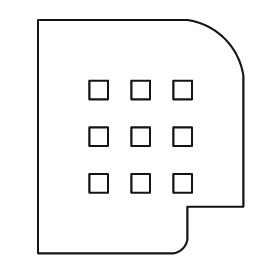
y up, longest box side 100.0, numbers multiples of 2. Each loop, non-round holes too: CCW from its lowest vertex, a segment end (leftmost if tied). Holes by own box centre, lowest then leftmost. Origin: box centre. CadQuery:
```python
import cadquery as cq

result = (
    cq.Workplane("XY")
    .moveTo(-44.0, -50.0)
    .lineTo(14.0, -50.0)
    .threePointArc((18.0, -48.0), (20.0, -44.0))
    .lineTo(20.0, -30.0)
    .lineTo(44.0, -30.0)
    .lineTo(44.0, 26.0)
    .threePointArc((36.0, 42.0), (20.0, 50.0))
    .lineTo(-44.0, 50.0)
    .close()
    .moveTo(-22.0, -24.0)
    .lineTo(-14.0, -24.0)
    .lineTo(-14.0, -16.0)
    .lineTo(-22.0, -16.0)
    .close()
    .moveTo(-4.0, -24.0)
    .lineTo(4.0, -24.0)
    .lineTo(4.0, -16.0)
    .lineTo(-4.0, -16.0)
    .close()
    .moveTo(14.0, -24.0)
    .lineTo(22.0, -24.0)
    .lineTo(22.0, -16.0)
    .lineTo(14.0, -16.0)
    .close()
    .moveTo(-22.0, -4.0)
    .lineTo(-14.0, -4.0)
    .lineTo(-14.0, 4.0)
    .lineTo(-22.0, 4.0)
    .close()
    .moveTo(-4.0, -4.0)
    .lineTo(4.0, -4.0)
    .lineTo(4.0, 4.0)
    .lineTo(-4.0, 4.0)
    .close()
    .moveTo(14.0, -4.0)
    .lineTo(22.0, -4.0)
    .lineTo(22.0, 4.0)
    .lineTo(14.0, 4.0)
    .close()
    .moveTo(-22.0, 16.0)
    .lineTo(-14.0, 16.0)
    .lineTo(-14.0, 24.0)
    .lineTo(-22.0, 24.0)
    .close()
    .moveTo(-4.0, 16.0)
    .lineTo(4.0, 16.0)
    .lineTo(4.0, 24.0)
    .lineTo(-4.0, 24.0)
    .close()
    .moveTo(14.0, 16.0)
    .lineTo(22.0, 16.0)
    .lineTo(22.0, 24.0)
    .lineTo(14.0, 24.0)
    .close()
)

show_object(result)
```